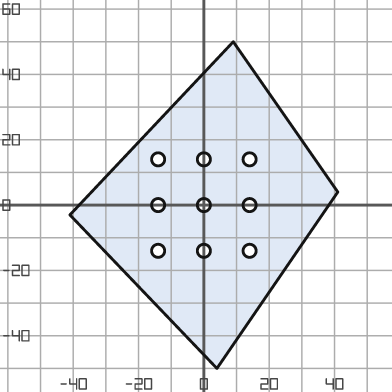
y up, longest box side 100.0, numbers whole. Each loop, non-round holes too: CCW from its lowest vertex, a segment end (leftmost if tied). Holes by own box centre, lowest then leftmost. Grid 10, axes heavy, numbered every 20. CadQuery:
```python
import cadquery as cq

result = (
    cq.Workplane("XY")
    .moveTo(4.0, -50.0)
    .lineTo(41.0, 4.0)
    .lineTo(9.0, 50.0)
    .lineTo(-41.0, -3.0)
    .close()
    .moveTo(-14.0, -14.0)
    .circle(2.0)
    .moveTo(0.0, -14.0)
    .circle(2.0)
    .moveTo(14.0, -14.0)
    .circle(2.0)
    .moveTo(-14.0, 0.0)
    .circle(2.0)
    .moveTo(0.0, 0.0)
    .circle(2.0)
    .moveTo(14.0, 0.0)
    .circle(2.0)
    .moveTo(-14.0, 14.0)
    .circle(2.0)
    .moveTo(0.0, 14.0)
    .circle(2.0)
    .moveTo(14.0, 14.0)
    .circle(2.0)
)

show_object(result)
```